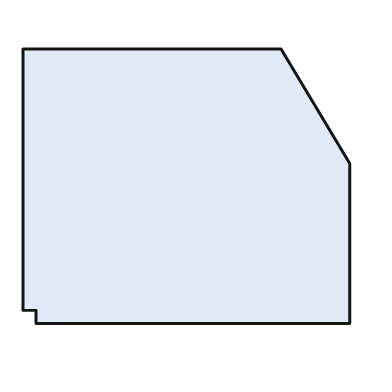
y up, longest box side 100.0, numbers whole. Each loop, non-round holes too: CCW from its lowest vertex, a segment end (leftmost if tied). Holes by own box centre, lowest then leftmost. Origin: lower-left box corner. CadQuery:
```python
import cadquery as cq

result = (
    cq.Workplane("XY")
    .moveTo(4.0, 0.0)
    .lineTo(100.0, 0.0)
    .lineTo(100.0, 49.0)
    .lineTo(79.0, 84.0)
    .lineTo(0.0, 84.0)
    .lineTo(0.0, 4.0)
    .lineTo(4.0, 4.0)
    .close()
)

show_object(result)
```